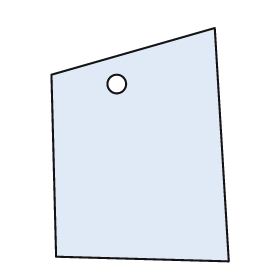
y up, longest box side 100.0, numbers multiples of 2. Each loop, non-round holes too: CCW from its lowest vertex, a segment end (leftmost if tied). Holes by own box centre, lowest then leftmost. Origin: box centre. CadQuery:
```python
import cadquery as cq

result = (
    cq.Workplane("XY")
    .moveTo(38.0, -50.0)
    .lineTo(32.0, 50.0)
    .lineTo(-38.0, 30.0)
    .lineTo(-36.0, -48.0)
    .close()
    .moveTo(-10.0, 26.0)
    .circle(4.0)
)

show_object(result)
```